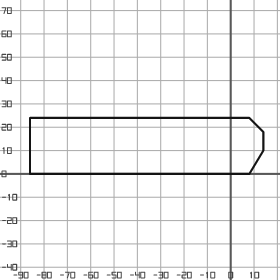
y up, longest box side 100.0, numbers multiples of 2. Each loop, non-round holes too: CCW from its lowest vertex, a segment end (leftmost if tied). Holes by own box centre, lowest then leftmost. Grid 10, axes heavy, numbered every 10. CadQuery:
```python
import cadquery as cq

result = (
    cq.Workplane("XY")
    .moveTo(-86.0, 0.0)
    .lineTo(8.0, 0.0)
    .lineTo(14.0, 10.0)
    .lineTo(14.0, 18.0)
    .lineTo(8.0, 24.0)
    .lineTo(-86.0, 24.0)
    .close()
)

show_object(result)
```